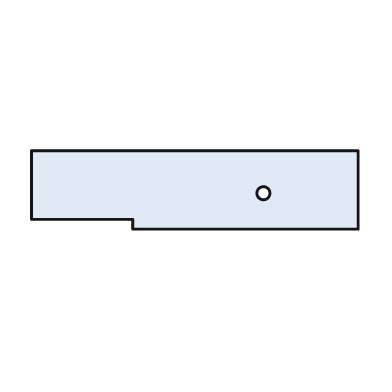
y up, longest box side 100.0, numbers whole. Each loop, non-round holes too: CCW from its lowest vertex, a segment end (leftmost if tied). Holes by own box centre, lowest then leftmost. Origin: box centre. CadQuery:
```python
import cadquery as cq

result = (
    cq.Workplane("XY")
    .moveTo(-19.0, -12.0)
    .lineTo(50.0, -12.0)
    .lineTo(50.0, 12.0)
    .lineTo(-50.0, 12.0)
    .lineTo(-50.0, -9.0)
    .lineTo(-19.0, -9.0)
    .close()
    .moveTo(21.0, -1.0)
    .circle(2.0)
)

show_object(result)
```